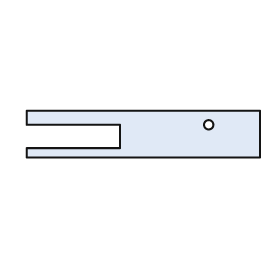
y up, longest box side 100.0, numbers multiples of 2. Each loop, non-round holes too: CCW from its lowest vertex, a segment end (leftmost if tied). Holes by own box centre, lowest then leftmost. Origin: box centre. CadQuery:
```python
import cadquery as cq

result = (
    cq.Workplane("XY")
    .moveTo(-50.0, -10.0)
    .lineTo(50.0, -10.0)
    .lineTo(50.0, 10.0)
    .lineTo(-50.0, 10.0)
    .lineTo(-50.0, 4.0)
    .lineTo(-10.0, 4.0)
    .lineTo(-10.0, -6.0)
    .lineTo(-50.0, -6.0)
    .close()
    .moveTo(28.0, 4.0)
    .circle(2.0)
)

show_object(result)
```